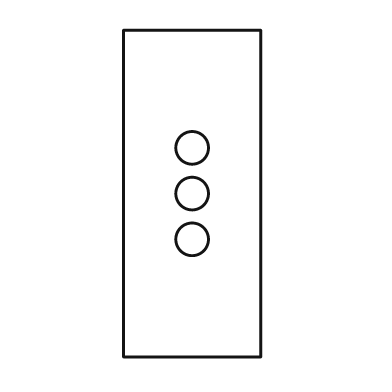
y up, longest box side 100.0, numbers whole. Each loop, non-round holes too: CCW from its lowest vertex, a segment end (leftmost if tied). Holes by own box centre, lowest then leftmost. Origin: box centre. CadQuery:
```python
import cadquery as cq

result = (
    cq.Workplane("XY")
    .moveTo(-21.0, -50.0)
    .lineTo(21.0, -50.0)
    .lineTo(21.0, 50.0)
    .lineTo(-21.0, 50.0)
    .close()
    .moveTo(0.0, -14.0)
    .circle(5.0)
    .moveTo(0.0, 0.0)
    .circle(5.0)
    .moveTo(0.0, 14.0)
    .circle(5.0)
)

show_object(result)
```